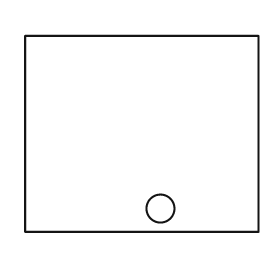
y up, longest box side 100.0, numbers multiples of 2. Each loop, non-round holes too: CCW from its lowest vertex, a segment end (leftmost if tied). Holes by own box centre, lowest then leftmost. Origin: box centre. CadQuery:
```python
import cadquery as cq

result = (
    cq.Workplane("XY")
    .moveTo(-50.0, -42.0)
    .lineTo(50.0, -42.0)
    .lineTo(50.0, 42.0)
    .lineTo(-50.0, 42.0)
    .close()
    .moveTo(8.0, -32.0)
    .circle(6.0)
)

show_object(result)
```